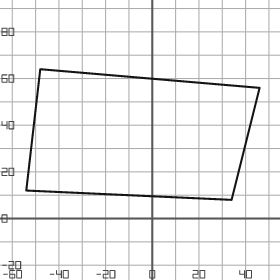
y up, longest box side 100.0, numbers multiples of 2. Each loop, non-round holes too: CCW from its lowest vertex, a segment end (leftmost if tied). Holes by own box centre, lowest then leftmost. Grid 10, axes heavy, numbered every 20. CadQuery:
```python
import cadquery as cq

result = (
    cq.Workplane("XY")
    .moveTo(34.0, 8.0)
    .lineTo(46.0, 56.0)
    .lineTo(-48.0, 64.0)
    .lineTo(-54.0, 12.0)
    .close()
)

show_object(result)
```